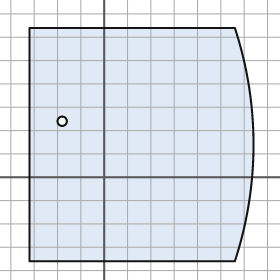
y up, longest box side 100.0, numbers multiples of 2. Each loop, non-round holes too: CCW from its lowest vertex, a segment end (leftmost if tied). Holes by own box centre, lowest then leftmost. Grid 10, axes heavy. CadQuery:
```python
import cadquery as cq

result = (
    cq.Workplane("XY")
    .moveTo(-32.0, -36.0)
    .lineTo(56.0, -36.0)
    .threePointArc((64.0, 14.0), (56.0, 64.0))
    .lineTo(-32.0, 64.0)
    .close()
    .moveTo(-18.0, 24.0)
    .circle(2.0)
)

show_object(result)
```